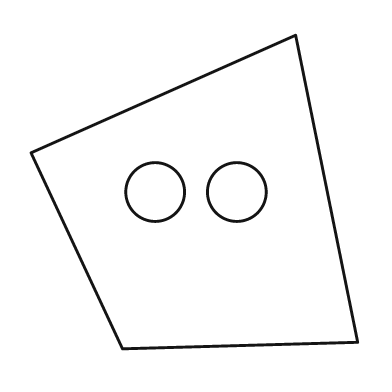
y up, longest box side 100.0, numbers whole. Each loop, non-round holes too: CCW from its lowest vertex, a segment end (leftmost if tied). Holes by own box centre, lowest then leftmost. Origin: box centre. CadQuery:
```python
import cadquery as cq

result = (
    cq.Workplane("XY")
    .moveTo(-22.0, -48.0)
    .lineTo(50.0, -46.0)
    .lineTo(31.0, 48.0)
    .lineTo(-50.0, 12.0)
    .close()
    .moveTo(-12.0, 0.0)
    .circle(9.0)
    .moveTo(13.0, 0.0)
    .circle(9.0)
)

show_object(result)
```